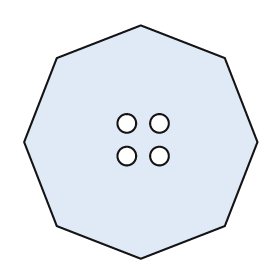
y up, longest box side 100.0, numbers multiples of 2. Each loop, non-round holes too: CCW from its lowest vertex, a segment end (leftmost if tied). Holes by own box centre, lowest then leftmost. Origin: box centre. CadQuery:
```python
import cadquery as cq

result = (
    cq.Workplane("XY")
    .moveTo(0.0, -50.0)
    .lineTo(36.0, -36.0)
    .lineTo(50.0, 0.0)
    .lineTo(36.0, 36.0)
    .lineTo(0.0, 50.0)
    .lineTo(-36.0, 36.0)
    .lineTo(-50.0, 0.0)
    .lineTo(-36.0, -36.0)
    .close()
    .moveTo(-6.0, -6.0)
    .circle(4.0)
    .moveTo(8.0, -6.0)
    .circle(4.0)
    .moveTo(-6.0, 8.0)
    .circle(4.0)
    .moveTo(8.0, 8.0)
    .circle(4.0)
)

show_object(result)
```